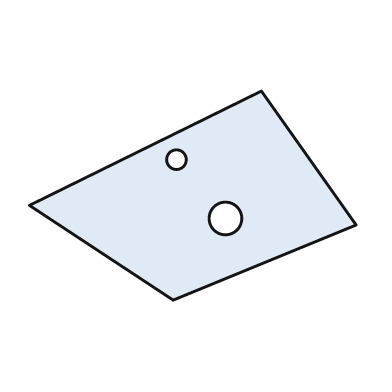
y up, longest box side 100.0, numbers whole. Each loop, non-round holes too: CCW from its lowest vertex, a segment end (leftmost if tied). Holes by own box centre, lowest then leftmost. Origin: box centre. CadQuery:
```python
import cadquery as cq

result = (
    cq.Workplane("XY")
    .moveTo(-6.0, -32.0)
    .lineTo(50.0, -9.0)
    .lineTo(21.0, 32.0)
    .lineTo(-50.0, -3.0)
    .close()
    .moveTo(10.0, -7.0)
    .circle(5.0)
    .moveTo(-5.0, 11.0)
    .circle(3.0)
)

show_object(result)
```